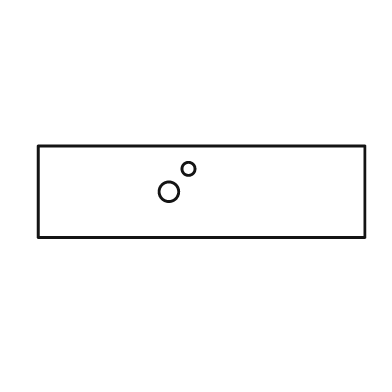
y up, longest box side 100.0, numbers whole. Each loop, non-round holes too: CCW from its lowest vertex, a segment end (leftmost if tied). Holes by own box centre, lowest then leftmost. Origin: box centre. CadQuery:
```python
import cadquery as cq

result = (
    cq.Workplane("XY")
    .moveTo(-50.0, -14.0)
    .lineTo(50.0, -14.0)
    .lineTo(50.0, 14.0)
    .lineTo(-50.0, 14.0)
    .close()
    .moveTo(-10.0, 0.0)
    .circle(3.0)
    .moveTo(-4.0, 7.0)
    .circle(2.0)
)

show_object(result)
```